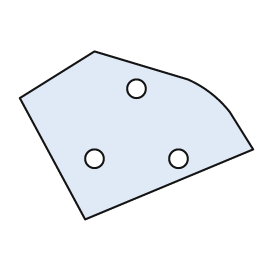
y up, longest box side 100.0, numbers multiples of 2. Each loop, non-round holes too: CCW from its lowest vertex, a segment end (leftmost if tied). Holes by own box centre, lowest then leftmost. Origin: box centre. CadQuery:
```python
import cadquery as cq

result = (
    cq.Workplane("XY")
    .moveTo(-22.0, -36.0)
    .lineTo(50.0, -6.0)
    .lineTo(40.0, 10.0)
    .threePointArc((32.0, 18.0), (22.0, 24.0))
    .lineTo(-18.0, 36.0)
    .lineTo(-50.0, 16.0)
    .close()
    .moveTo(-18.0, -10.0)
    .circle(4.0)
    .moveTo(18.0, -10.0)
    .circle(4.0)
    .moveTo(0.0, 20.0)
    .circle(4.0)
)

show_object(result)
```